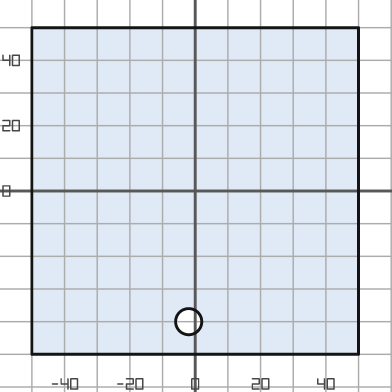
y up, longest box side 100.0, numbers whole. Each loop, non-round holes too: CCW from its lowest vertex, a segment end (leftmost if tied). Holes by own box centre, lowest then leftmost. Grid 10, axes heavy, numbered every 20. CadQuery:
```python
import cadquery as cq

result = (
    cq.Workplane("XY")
    .moveTo(-50.0, -50.0)
    .lineTo(50.0, -50.0)
    .lineTo(50.0, 50.0)
    .lineTo(-50.0, 50.0)
    .close()
    .moveTo(-2.0, -40.0)
    .circle(4.0)
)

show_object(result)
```